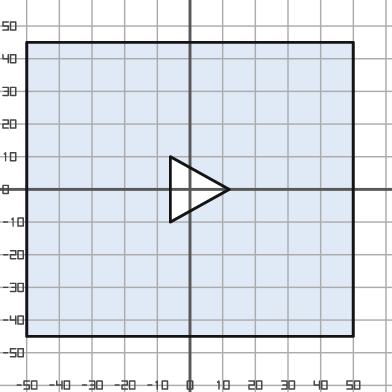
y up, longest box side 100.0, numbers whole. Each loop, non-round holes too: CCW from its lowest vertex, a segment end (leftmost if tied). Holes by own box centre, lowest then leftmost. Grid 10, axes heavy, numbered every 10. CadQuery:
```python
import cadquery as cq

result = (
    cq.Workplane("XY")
    .moveTo(-50.0, -45.0)
    .lineTo(50.0, -45.0)
    .lineTo(50.0, 45.0)
    .lineTo(-50.0, 45.0)
    .close()
    .moveTo(-6.0, -10.0)
    .lineTo(12.0, 0.0)
    .lineTo(-6.0, 10.0)
    .close()
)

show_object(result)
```